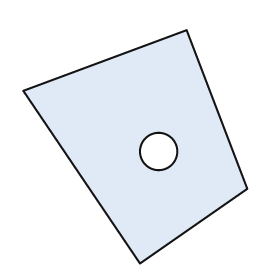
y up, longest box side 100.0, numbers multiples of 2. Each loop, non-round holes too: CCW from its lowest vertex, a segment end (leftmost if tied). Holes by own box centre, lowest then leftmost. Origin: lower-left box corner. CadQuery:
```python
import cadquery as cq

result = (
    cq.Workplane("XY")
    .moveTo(50.0, 0.0)
    .lineTo(96.0, 32.0)
    .lineTo(70.0, 100.0)
    .lineTo(0.0, 74.0)
    .close()
    .moveTo(58.0, 48.0)
    .circle(8.0)
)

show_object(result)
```